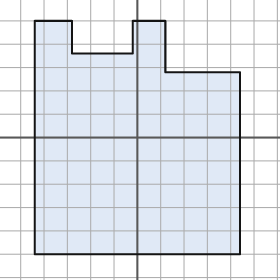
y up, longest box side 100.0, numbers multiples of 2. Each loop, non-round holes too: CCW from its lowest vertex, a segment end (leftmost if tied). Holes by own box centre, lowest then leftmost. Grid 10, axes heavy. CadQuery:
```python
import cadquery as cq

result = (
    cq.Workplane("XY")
    .moveTo(-44.0, -50.0)
    .lineTo(44.0, -50.0)
    .lineTo(44.0, 28.0)
    .lineTo(12.0, 28.0)
    .lineTo(12.0, 50.0)
    .lineTo(-2.0, 50.0)
    .lineTo(-2.0, 36.0)
    .lineTo(-28.0, 36.0)
    .lineTo(-28.0, 50.0)
    .lineTo(-44.0, 50.0)
    .close()
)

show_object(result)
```